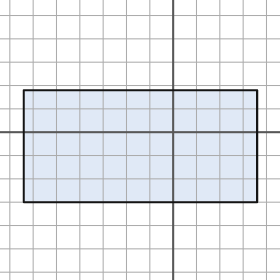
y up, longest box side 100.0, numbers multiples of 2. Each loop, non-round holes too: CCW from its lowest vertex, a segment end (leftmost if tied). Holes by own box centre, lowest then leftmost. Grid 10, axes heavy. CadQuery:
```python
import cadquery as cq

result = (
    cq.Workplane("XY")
    .moveTo(-64.0, -30.0)
    .lineTo(36.0, -30.0)
    .lineTo(36.0, 18.0)
    .lineTo(-64.0, 18.0)
    .close()
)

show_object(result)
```